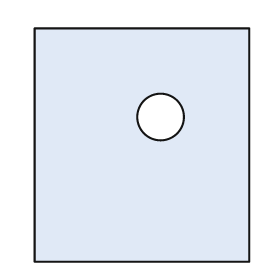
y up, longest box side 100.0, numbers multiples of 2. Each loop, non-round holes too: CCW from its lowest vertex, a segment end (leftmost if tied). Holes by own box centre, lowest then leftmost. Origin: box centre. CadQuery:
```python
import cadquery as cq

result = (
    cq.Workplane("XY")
    .moveTo(-46.0, -50.0)
    .lineTo(46.0, -50.0)
    .lineTo(46.0, 50.0)
    .lineTo(-46.0, 50.0)
    .close()
    .moveTo(8.0, 12.0)
    .circle(10.0)
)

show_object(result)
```